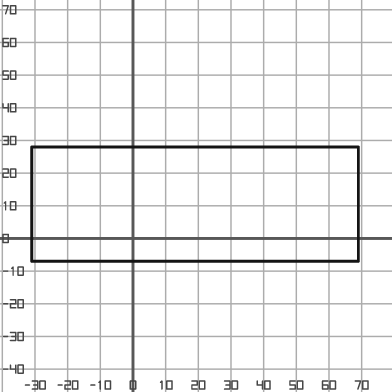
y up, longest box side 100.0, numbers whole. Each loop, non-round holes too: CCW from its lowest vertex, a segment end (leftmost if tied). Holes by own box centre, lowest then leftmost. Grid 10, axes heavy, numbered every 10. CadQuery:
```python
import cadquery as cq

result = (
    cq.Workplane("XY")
    .moveTo(-31.0, -7.0)
    .lineTo(69.0, -7.0)
    .lineTo(69.0, 28.0)
    .lineTo(-31.0, 28.0)
    .close()
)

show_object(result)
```